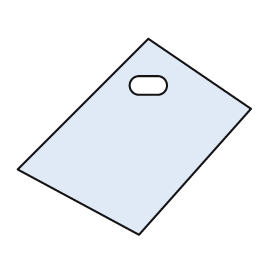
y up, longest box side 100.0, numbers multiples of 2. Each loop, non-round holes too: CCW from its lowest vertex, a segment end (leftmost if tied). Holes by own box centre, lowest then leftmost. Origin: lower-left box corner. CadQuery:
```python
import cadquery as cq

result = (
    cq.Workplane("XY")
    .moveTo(52.0, 0.0)
    .lineTo(100.0, 54.0)
    .lineTo(56.0, 84.0)
    .lineTo(0.0, 28.0)
    .close()
    .moveTo(52.0, 60.0)
    .lineTo(60.0, 60.0)
    .threePointArc((64.0, 64.0), (60.0, 68.0))
    .lineTo(52.0, 68.0)
    .threePointArc((48.0, 64.0), (52.0, 60.0))
    .close()
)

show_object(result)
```